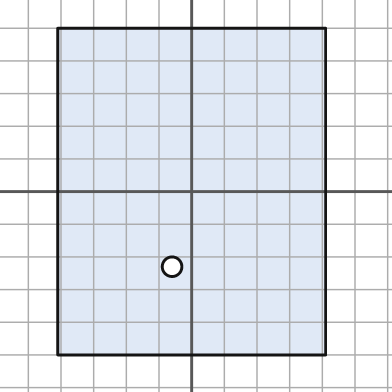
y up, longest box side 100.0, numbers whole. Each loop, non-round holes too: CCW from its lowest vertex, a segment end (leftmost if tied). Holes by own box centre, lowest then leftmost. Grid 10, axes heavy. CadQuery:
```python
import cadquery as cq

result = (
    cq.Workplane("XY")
    .moveTo(-41.0, -50.0)
    .lineTo(41.0, -50.0)
    .lineTo(41.0, 50.0)
    .lineTo(-41.0, 50.0)
    .close()
    .moveTo(-6.0, -23.0)
    .circle(3.0)
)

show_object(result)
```